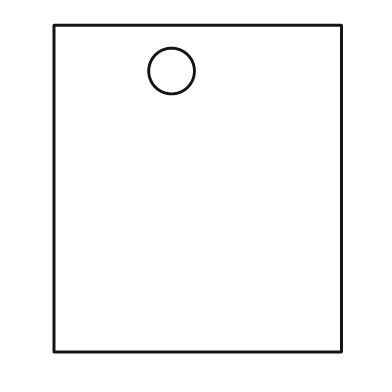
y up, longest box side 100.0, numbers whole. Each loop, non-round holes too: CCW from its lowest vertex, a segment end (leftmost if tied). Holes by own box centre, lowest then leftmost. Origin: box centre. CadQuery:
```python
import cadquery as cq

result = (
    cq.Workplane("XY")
    .moveTo(-44.0, -50.0)
    .lineTo(44.0, -50.0)
    .lineTo(44.0, 50.0)
    .lineTo(-44.0, 50.0)
    .close()
    .moveTo(-8.0, 36.0)
    .circle(7.0)
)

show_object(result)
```